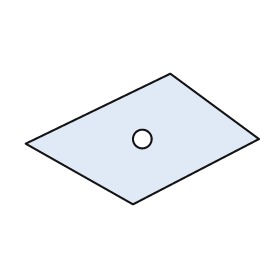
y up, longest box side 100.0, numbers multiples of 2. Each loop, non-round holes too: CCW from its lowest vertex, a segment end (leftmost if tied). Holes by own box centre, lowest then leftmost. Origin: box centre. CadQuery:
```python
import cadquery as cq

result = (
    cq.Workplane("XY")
    .moveTo(-4.0, -28.0)
    .lineTo(50.0, 0.0)
    .lineTo(12.0, 28.0)
    .lineTo(-50.0, -2.0)
    .close()
    .moveTo(0.0, 0.0)
    .circle(4.0)
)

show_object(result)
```